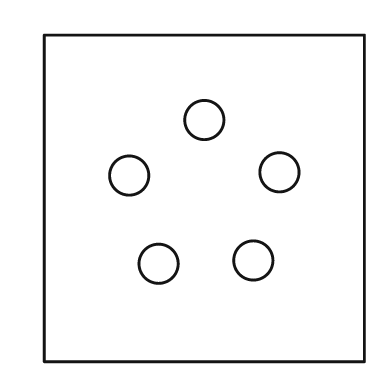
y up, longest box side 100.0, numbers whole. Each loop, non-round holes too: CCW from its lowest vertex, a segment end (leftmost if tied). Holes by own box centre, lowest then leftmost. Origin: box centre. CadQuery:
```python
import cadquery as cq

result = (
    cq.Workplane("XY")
    .moveTo(-49.0, -50.0)
    .lineTo(49.0, -50.0)
    .lineTo(49.0, 50.0)
    .lineTo(-49.0, 50.0)
    .close()
    .moveTo(-14.0, -20.0)
    .circle(6.0)
    .moveTo(15.0, -19.0)
    .circle(6.0)
    .moveTo(-23.0, 7.0)
    .circle(6.0)
    .moveTo(23.0, 8.0)
    .circle(6.0)
    .moveTo(0.0, 24.0)
    .circle(6.0)
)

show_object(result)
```